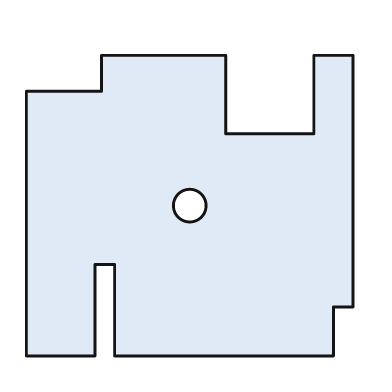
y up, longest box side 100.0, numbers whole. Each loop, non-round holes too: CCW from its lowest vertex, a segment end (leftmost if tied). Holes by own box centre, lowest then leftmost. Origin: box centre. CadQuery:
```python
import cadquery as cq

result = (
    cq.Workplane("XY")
    .moveTo(-50.0, -46.0)
    .lineTo(-29.0, -46.0)
    .lineTo(-29.0, -18.0)
    .lineTo(-23.0, -18.0)
    .lineTo(-23.0, -46.0)
    .lineTo(44.0, -46.0)
    .lineTo(44.0, -31.0)
    .lineTo(50.0, -31.0)
    .lineTo(50.0, 46.0)
    .lineTo(38.0, 46.0)
    .lineTo(38.0, 22.0)
    .lineTo(11.0, 22.0)
    .lineTo(11.0, 46.0)
    .lineTo(-27.0, 46.0)
    .lineTo(-27.0, 35.0)
    .lineTo(-50.0, 35.0)
    .close()
    .moveTo(0.0, 0.0)
    .circle(5.0)
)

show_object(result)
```